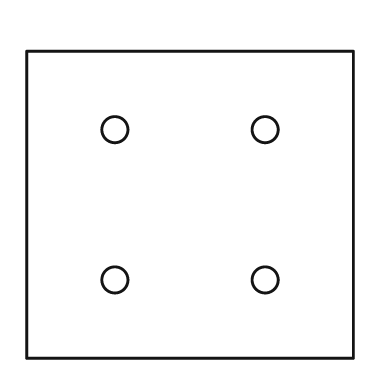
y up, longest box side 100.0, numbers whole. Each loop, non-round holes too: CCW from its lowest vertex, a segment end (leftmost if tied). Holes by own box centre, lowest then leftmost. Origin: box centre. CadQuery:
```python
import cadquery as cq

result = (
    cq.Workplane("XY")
    .moveTo(-50.0, -47.0)
    .lineTo(50.0, -47.0)
    .lineTo(50.0, 47.0)
    .lineTo(-50.0, 47.0)
    .close()
    .moveTo(-23.0, -23.0)
    .circle(4.0)
    .moveTo(23.0, -23.0)
    .circle(4.0)
    .moveTo(-23.0, 23.0)
    .circle(4.0)
    .moveTo(23.0, 23.0)
    .circle(4.0)
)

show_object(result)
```